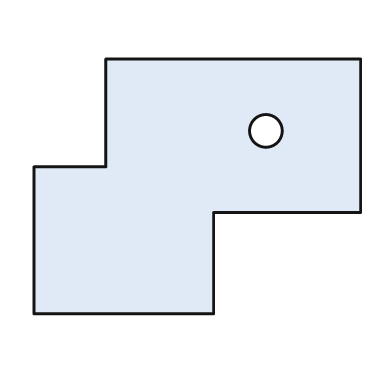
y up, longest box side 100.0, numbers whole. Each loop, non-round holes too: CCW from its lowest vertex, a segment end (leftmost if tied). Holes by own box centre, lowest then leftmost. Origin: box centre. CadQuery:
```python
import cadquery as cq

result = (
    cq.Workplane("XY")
    .moveTo(-50.0, -39.0)
    .lineTo(5.0, -39.0)
    .lineTo(5.0, -8.0)
    .lineTo(50.0, -8.0)
    .lineTo(50.0, 39.0)
    .lineTo(-28.0, 39.0)
    .lineTo(-28.0, 6.0)
    .lineTo(-50.0, 6.0)
    .close()
    .moveTo(21.0, 17.0)
    .circle(5.0)
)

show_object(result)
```